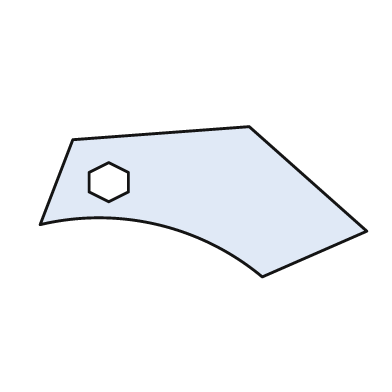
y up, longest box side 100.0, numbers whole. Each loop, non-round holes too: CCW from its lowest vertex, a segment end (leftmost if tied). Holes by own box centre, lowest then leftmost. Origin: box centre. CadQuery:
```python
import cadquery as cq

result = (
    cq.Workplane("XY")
    .moveTo(18.0, -23.0)
    .lineTo(50.0, -9.0)
    .lineTo(14.0, 23.0)
    .lineTo(-40.0, 19.0)
    .lineTo(-50.0, -7.0)
    .threePointArc((-14.0, -7.0), (18.0, -23.0))
    .close()
    .moveTo(-29.0, 0.0)
    .lineTo(-23.0, 3.0)
    .lineTo(-23.0, 9.0)
    .lineTo(-29.0, 12.0)
    .lineTo(-35.0, 9.0)
    .lineTo(-35.0, 3.0)
    .close()
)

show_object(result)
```